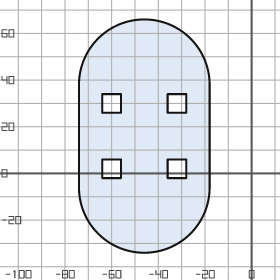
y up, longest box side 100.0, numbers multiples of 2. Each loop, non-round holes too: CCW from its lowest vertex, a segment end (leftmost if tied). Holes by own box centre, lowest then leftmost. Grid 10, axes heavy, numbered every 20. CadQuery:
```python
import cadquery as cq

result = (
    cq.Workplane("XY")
    .moveTo(-74.0, -6.0)
    .threePointArc((-46.0, -34.0), (-18.0, -6.0))
    .lineTo(-18.0, 38.0)
    .threePointArc((-46.0, 66.0), (-74.0, 38.0))
    .close()
    .moveTo(-64.0, -2.0)
    .lineTo(-56.0, -2.0)
    .lineTo(-56.0, 6.0)
    .lineTo(-64.0, 6.0)
    .close()
    .moveTo(-36.0, -2.0)
    .lineTo(-28.0, -2.0)
    .lineTo(-28.0, 6.0)
    .lineTo(-36.0, 6.0)
    .close()
    .moveTo(-64.0, 26.0)
    .lineTo(-56.0, 26.0)
    .lineTo(-56.0, 34.0)
    .lineTo(-64.0, 34.0)
    .close()
    .moveTo(-36.0, 26.0)
    .lineTo(-28.0, 26.0)
    .lineTo(-28.0, 34.0)
    .lineTo(-36.0, 34.0)
    .close()
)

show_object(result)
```